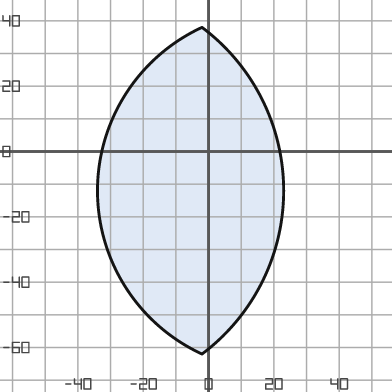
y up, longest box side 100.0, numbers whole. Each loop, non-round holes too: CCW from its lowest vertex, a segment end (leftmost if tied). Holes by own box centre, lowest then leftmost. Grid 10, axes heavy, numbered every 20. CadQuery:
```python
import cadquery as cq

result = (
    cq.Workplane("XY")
    .moveTo(-2.0, -62.0)
    .threePointArc((23.0, -12.0), (-2.0, 38.0))
    .threePointArc((-34.0, -12.0), (-2.0, -62.0))
    .close()
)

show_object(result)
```